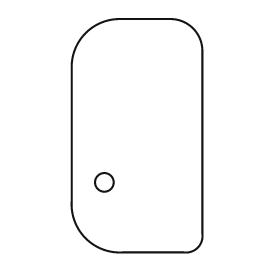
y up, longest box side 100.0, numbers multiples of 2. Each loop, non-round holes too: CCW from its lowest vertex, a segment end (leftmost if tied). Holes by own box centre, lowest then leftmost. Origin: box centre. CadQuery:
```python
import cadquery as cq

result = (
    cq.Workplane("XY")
    .moveTo(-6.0, -50.0)
    .lineTo(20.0, -50.0)
    .threePointArc((26.0, -48.0), (28.0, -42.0))
    .lineTo(28.0, 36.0)
    .threePointArc((24.0, 46.0), (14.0, 50.0))
    .lineTo(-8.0, 50.0)
    .threePointArc((-22.0, 44.0), (-28.0, 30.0))
    .lineTo(-28.0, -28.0)
    .threePointArc((-22.0, -44.0), (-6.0, -50.0))
    .close()
    .moveTo(-14.0, -20.0)
    .circle(4.0)
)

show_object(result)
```